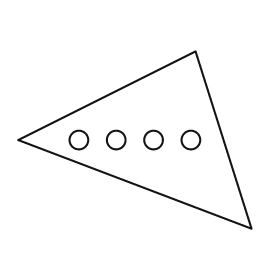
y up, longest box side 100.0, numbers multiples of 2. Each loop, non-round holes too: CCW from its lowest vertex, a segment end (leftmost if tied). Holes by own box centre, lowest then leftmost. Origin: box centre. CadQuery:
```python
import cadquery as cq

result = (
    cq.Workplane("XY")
    .moveTo(50.0, -38.0)
    .lineTo(26.0, 38.0)
    .lineTo(-50.0, 0.0)
    .close()
    .moveTo(-24.0, 0.0)
    .circle(4.0)
    .moveTo(-8.0, 0.0)
    .circle(4.0)
    .moveTo(8.0, 0.0)
    .circle(4.0)
    .moveTo(24.0, 0.0)
    .circle(4.0)
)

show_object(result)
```